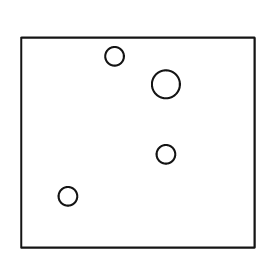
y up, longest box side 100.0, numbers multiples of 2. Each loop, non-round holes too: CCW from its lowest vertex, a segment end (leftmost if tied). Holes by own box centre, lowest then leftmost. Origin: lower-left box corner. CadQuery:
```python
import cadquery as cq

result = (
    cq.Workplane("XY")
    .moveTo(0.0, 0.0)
    .lineTo(100.0, 0.0)
    .lineTo(100.0, 90.0)
    .lineTo(0.0, 90.0)
    .close()
    .moveTo(20.0, 22.0)
    .circle(4.0)
    .moveTo(62.0, 40.0)
    .circle(4.0)
    .moveTo(62.0, 70.0)
    .circle(6.0)
    .moveTo(40.0, 82.0)
    .circle(4.0)
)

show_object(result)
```